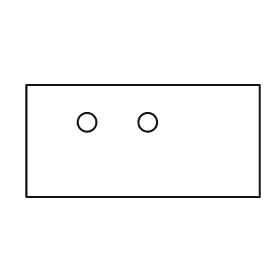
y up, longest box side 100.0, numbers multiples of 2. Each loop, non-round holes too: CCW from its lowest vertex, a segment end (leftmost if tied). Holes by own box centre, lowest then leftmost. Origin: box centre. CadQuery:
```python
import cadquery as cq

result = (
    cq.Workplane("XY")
    .moveTo(-50.0, -24.0)
    .lineTo(50.0, -24.0)
    .lineTo(50.0, 24.0)
    .lineTo(-50.0, 24.0)
    .close()
    .moveTo(-24.0, 8.0)
    .circle(4.0)
    .moveTo(2.0, 8.0)
    .circle(4.0)
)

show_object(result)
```